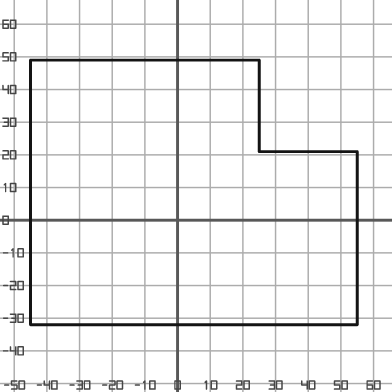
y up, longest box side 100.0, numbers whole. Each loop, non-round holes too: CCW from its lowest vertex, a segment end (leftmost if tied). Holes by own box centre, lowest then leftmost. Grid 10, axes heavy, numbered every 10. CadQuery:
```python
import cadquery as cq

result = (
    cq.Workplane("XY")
    .moveTo(-45.0, -32.0)
    .lineTo(55.0, -32.0)
    .lineTo(55.0, 21.0)
    .lineTo(25.0, 21.0)
    .lineTo(25.0, 49.0)
    .lineTo(-45.0, 49.0)
    .close()
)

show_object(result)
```